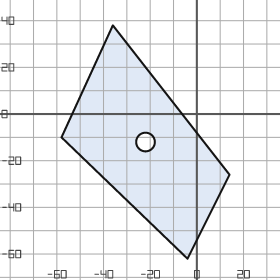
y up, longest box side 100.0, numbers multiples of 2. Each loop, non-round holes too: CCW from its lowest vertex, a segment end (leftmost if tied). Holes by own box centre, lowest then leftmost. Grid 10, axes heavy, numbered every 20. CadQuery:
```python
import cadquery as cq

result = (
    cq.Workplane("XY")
    .moveTo(-4.0, -62.0)
    .lineTo(14.0, -26.0)
    .lineTo(-36.0, 38.0)
    .lineTo(-58.0, -10.0)
    .close()
    .moveTo(-22.0, -12.0)
    .circle(4.0)
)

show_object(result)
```